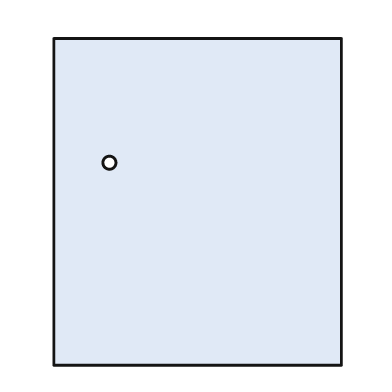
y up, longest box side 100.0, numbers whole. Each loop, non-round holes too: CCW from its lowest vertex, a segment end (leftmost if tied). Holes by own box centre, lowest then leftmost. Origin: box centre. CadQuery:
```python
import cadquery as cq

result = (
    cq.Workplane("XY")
    .moveTo(-44.0, -50.0)
    .lineTo(44.0, -50.0)
    .lineTo(44.0, 50.0)
    .lineTo(-44.0, 50.0)
    .close()
    .moveTo(-27.0, 12.0)
    .circle(2.0)
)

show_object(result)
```